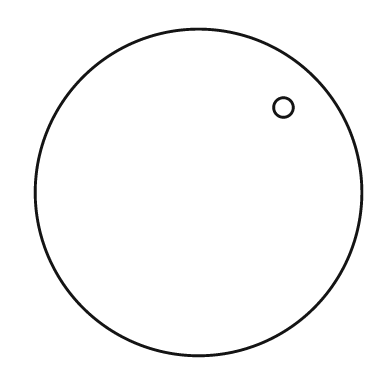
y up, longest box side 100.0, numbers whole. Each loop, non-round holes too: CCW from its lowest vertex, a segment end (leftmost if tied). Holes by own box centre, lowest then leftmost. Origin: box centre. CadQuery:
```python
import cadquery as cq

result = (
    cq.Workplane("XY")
    .moveTo(0.0, 0.0)
    .circle(50.0)
    .moveTo(26.0, 26.0)
    .circle(3.0)
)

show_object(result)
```